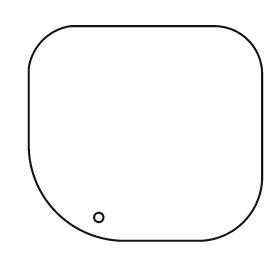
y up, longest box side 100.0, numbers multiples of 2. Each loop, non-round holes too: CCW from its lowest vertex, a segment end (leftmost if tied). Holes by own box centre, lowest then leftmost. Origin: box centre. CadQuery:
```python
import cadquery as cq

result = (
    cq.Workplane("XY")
    .moveTo(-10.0, -46.0)
    .lineTo(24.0, -46.0)
    .threePointArc((42.0, -38.0), (50.0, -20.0))
    .lineTo(50.0, 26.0)
    .threePointArc((44.0, 40.0), (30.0, 46.0))
    .lineTo(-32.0, 46.0)
    .threePointArc((-44.0, 40.0), (-50.0, 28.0))
    .lineTo(-50.0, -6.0)
    .threePointArc((-38.0, -34.0), (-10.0, -46.0))
    .close()
    .moveTo(-20.0, -36.0)
    .circle(2.0)
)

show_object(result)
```